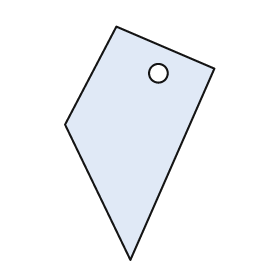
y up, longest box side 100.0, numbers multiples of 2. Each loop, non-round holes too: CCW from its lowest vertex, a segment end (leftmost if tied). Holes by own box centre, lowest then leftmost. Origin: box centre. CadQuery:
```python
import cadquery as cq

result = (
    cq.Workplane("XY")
    .moveTo(-4.0, -50.0)
    .lineTo(32.0, 32.0)
    .lineTo(-10.0, 50.0)
    .lineTo(-32.0, 8.0)
    .close()
    .moveTo(8.0, 30.0)
    .circle(4.0)
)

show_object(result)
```